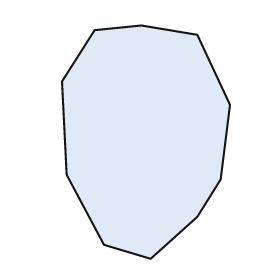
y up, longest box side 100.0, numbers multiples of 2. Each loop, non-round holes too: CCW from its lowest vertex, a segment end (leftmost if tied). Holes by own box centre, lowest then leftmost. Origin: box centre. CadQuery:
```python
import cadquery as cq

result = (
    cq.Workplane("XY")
    .moveTo(2.0, -50.0)
    .lineTo(22.0, -32.0)
    .lineTo(32.0, -16.0)
    .lineTo(36.0, 16.0)
    .lineTo(22.0, 46.0)
    .lineTo(-2.0, 50.0)
    .lineTo(-22.0, 48.0)
    .lineTo(-36.0, 26.0)
    .lineTo(-34.0, -14.0)
    .lineTo(-18.0, -44.0)
    .close()
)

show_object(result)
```